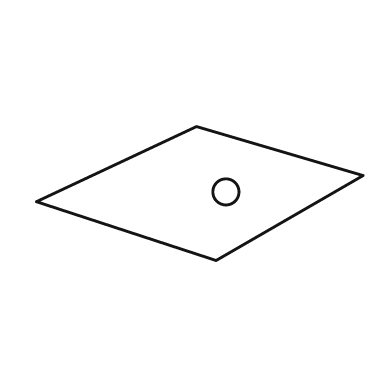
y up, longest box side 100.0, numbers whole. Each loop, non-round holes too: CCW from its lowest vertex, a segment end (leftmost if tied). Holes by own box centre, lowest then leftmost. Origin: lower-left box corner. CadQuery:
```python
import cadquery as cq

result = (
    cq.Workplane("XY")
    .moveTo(55.0, 0.0)
    .lineTo(100.0, 26.0)
    .lineTo(49.0, 41.0)
    .lineTo(0.0, 18.0)
    .close()
    .moveTo(58.0, 21.0)
    .circle(4.0)
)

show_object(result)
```